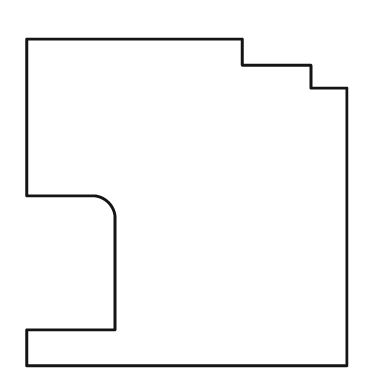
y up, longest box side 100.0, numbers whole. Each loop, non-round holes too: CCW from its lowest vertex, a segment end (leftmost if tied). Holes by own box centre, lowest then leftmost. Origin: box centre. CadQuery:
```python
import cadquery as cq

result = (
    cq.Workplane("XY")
    .moveTo(-49.0, -50.0)
    .lineTo(49.0, -50.0)
    .lineTo(49.0, 35.0)
    .lineTo(38.0, 35.0)
    .lineTo(38.0, 42.0)
    .lineTo(17.0, 42.0)
    .lineTo(17.0, 50.0)
    .lineTo(-49.0, 50.0)
    .lineTo(-49.0, 2.0)
    .lineTo(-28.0, 2.0)
    .threePointArc((-24.0, 0.0), (-22.0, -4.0))
    .lineTo(-22.0, -39.0)
    .lineTo(-49.0, -39.0)
    .close()
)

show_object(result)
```